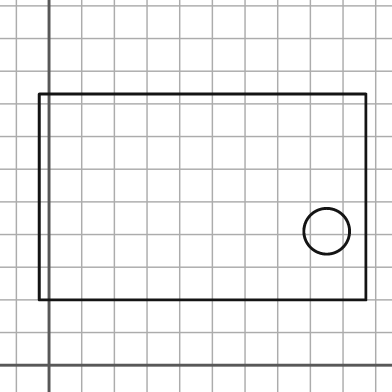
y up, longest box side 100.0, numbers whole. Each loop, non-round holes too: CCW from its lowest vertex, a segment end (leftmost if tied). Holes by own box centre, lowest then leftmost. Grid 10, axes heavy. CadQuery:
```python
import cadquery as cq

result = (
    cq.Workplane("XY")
    .moveTo(-3.0, 20.0)
    .lineTo(97.0, 20.0)
    .lineTo(97.0, 83.0)
    .lineTo(-3.0, 83.0)
    .close()
    .moveTo(85.0, 41.0)
    .circle(7.0)
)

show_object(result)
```